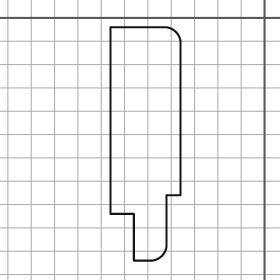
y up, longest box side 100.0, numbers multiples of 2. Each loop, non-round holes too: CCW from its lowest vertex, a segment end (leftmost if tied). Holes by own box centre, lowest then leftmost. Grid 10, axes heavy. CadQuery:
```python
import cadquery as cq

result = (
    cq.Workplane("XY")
    .moveTo(-56.0, -104.0)
    .lineTo(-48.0, -104.0)
    .threePointArc((-44.0, -102.0), (-42.0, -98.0))
    .lineTo(-42.0, -76.0)
    .lineTo(-36.0, -76.0)
    .lineTo(-36.0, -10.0)
    .threePointArc((-38.0, -6.0), (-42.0, -4.0))
    .lineTo(-66.0, -4.0)
    .lineTo(-66.0, -84.0)
    .lineTo(-56.0, -84.0)
    .close()
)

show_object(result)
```